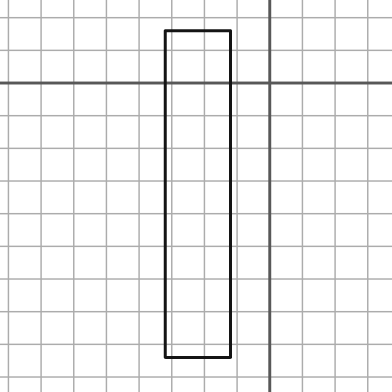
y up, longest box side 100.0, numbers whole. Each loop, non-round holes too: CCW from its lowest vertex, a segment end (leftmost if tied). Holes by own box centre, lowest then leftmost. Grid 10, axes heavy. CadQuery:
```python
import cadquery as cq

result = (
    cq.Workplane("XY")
    .moveTo(-32.0, -84.0)
    .lineTo(-12.0, -84.0)
    .lineTo(-12.0, 16.0)
    .lineTo(-32.0, 16.0)
    .close()
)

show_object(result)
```